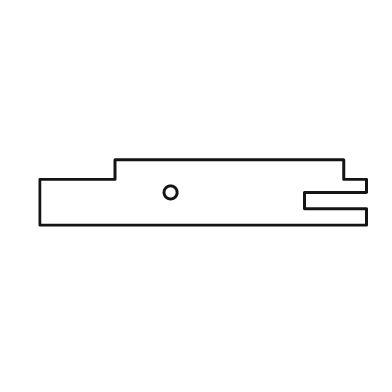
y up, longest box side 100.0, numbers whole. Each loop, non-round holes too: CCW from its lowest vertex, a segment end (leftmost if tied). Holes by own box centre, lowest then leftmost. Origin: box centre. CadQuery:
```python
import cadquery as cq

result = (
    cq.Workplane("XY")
    .moveTo(-50.0, -10.0)
    .lineTo(50.0, -10.0)
    .lineTo(50.0, -5.0)
    .lineTo(31.0, -5.0)
    .lineTo(31.0, 0.0)
    .lineTo(50.0, 0.0)
    .lineTo(50.0, 4.0)
    .lineTo(43.0, 4.0)
    .lineTo(43.0, 10.0)
    .lineTo(-27.0, 10.0)
    .lineTo(-27.0, 4.0)
    .lineTo(-50.0, 4.0)
    .close()
    .moveTo(-10.0, 0.0)
    .circle(2.0)
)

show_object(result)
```